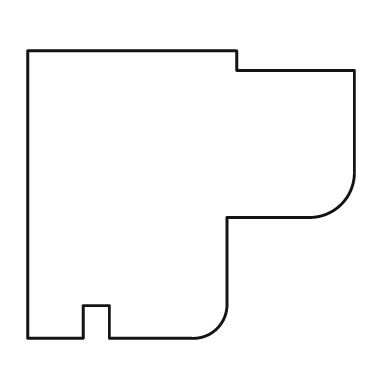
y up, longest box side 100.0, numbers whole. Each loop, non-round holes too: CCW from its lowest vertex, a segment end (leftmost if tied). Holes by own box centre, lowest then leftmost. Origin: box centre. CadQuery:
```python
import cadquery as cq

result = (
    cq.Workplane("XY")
    .moveTo(-50.0, -44.0)
    .lineTo(-33.0, -44.0)
    .lineTo(-33.0, -34.0)
    .lineTo(-25.0, -34.0)
    .lineTo(-25.0, -44.0)
    .lineTo(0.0, -44.0)
    .threePointArc((8.0, -41.0), (11.0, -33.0))
    .lineTo(11.0, -7.0)
    .lineTo(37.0, -7.0)
    .threePointArc((46.0, -3.0), (50.0, 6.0))
    .lineTo(50.0, 38.0)
    .lineTo(14.0, 38.0)
    .lineTo(14.0, 44.0)
    .lineTo(-50.0, 44.0)
    .close()
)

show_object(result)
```